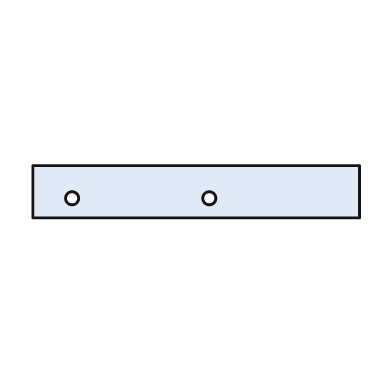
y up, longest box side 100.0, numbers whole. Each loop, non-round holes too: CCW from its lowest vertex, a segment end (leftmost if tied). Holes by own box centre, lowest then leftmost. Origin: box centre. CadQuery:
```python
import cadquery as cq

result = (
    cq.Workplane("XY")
    .moveTo(-50.0, -8.0)
    .lineTo(50.0, -8.0)
    .lineTo(50.0, 8.0)
    .lineTo(-50.0, 8.0)
    .close()
    .moveTo(-38.0, -2.0)
    .circle(2.0)
    .moveTo(4.0, -2.0)
    .circle(2.0)
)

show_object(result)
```